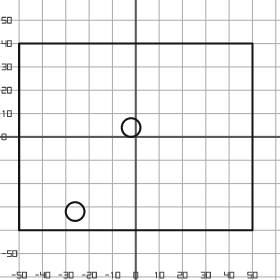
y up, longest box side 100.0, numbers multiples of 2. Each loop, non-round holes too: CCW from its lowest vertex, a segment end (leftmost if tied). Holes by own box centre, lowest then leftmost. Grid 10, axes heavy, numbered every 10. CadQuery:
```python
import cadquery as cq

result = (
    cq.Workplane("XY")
    .moveTo(-50.0, -40.0)
    .lineTo(50.0, -40.0)
    .lineTo(50.0, 40.0)
    .lineTo(-50.0, 40.0)
    .close()
    .moveTo(-26.0, -32.0)
    .circle(4.0)
    .moveTo(-2.0, 4.0)
    .circle(4.0)
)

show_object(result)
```